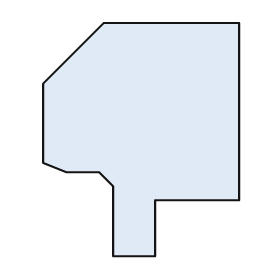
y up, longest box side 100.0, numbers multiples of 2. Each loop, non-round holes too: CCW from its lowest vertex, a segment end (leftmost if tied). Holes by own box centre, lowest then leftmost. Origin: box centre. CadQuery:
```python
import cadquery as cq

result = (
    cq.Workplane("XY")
    .moveTo(-12.0, -50.0)
    .lineTo(6.0, -50.0)
    .lineTo(6.0, -26.0)
    .lineTo(42.0, -26.0)
    .lineTo(42.0, 50.0)
    .lineTo(-16.0, 50.0)
    .lineTo(-42.0, 24.0)
    .lineTo(-42.0, -10.0)
    .lineTo(-32.0, -14.0)
    .lineTo(-18.0, -14.0)
    .lineTo(-12.0, -20.0)
    .close()
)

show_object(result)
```